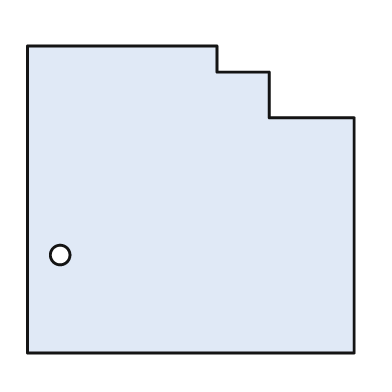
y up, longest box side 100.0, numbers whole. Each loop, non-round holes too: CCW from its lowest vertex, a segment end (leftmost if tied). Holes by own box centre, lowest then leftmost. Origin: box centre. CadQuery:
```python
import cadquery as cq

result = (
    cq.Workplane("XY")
    .moveTo(-50.0, -47.0)
    .lineTo(50.0, -47.0)
    .lineTo(50.0, 25.0)
    .lineTo(24.0, 25.0)
    .lineTo(24.0, 39.0)
    .lineTo(8.0, 39.0)
    .lineTo(8.0, 47.0)
    .lineTo(-50.0, 47.0)
    .close()
    .moveTo(-40.0, -17.0)
    .circle(3.0)
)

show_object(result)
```